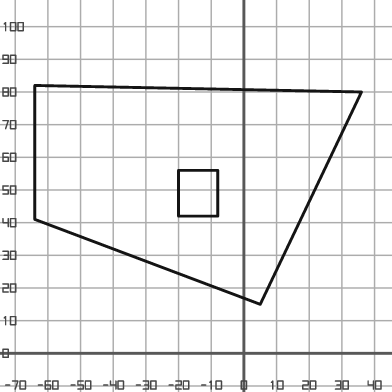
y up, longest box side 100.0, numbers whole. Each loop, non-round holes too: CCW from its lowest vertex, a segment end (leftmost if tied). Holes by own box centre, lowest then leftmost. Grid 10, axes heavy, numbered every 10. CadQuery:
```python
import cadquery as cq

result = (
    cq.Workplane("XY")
    .moveTo(5.0, 15.0)
    .lineTo(36.0, 80.0)
    .lineTo(-64.0, 82.0)
    .lineTo(-64.0, 41.0)
    .close()
    .moveTo(-20.0, 42.0)
    .lineTo(-8.0, 42.0)
    .lineTo(-8.0, 56.0)
    .lineTo(-20.0, 56.0)
    .close()
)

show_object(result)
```